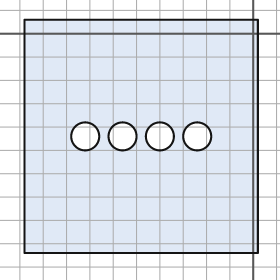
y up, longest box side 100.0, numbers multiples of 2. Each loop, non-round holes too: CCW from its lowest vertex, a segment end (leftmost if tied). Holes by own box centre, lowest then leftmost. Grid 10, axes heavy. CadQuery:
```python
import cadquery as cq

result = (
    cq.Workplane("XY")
    .moveTo(-98.0, -94.0)
    .lineTo(2.0, -94.0)
    .lineTo(2.0, 6.0)
    .lineTo(-98.0, 6.0)
    .close()
    .moveTo(-72.0, -44.0)
    .circle(6.0)
    .moveTo(-56.0, -44.0)
    .circle(6.0)
    .moveTo(-40.0, -44.0)
    .circle(6.0)
    .moveTo(-24.0, -44.0)
    .circle(6.0)
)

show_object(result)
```